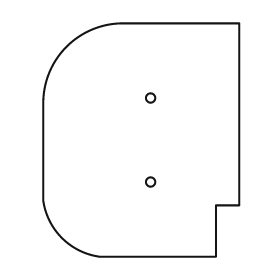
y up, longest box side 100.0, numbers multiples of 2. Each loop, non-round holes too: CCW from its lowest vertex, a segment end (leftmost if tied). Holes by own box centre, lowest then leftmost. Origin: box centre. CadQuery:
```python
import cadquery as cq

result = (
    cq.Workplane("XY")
    .moveTo(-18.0, -50.0)
    .lineTo(32.0, -50.0)
    .lineTo(32.0, -28.0)
    .lineTo(42.0, -28.0)
    .lineTo(42.0, 50.0)
    .lineTo(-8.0, 50.0)
    .threePointArc((-32.0, 40.0), (-42.0, 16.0))
    .lineTo(-42.0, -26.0)
    .threePointArc((-34.0, -42.0), (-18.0, -50.0))
    .close()
    .moveTo(4.0, -18.0)
    .circle(2.0)
    .moveTo(4.0, 18.0)
    .circle(2.0)
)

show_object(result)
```